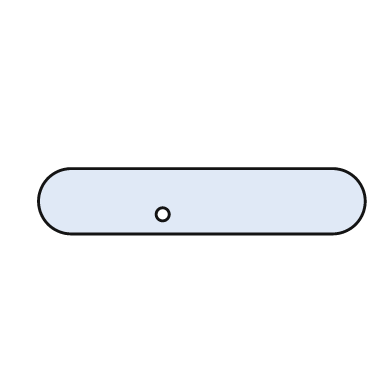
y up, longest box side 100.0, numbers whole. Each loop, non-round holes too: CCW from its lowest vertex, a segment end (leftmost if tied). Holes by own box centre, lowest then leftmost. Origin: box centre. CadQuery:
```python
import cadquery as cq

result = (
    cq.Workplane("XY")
    .moveTo(-40.0, -10.0)
    .lineTo(40.0, -10.0)
    .threePointArc((50.0, 0.0), (40.0, 10.0))
    .lineTo(-40.0, 10.0)
    .threePointArc((-50.0, 0.0), (-40.0, -10.0))
    .close()
    .moveTo(-12.0, -4.0)
    .circle(2.0)
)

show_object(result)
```